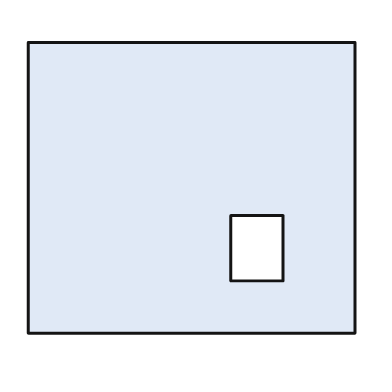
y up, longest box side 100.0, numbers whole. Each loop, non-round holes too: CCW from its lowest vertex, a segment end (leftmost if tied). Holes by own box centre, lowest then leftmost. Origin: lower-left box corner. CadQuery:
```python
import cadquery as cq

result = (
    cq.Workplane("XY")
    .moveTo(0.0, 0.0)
    .lineTo(100.0, 0.0)
    .lineTo(100.0, 89.0)
    .lineTo(0.0, 89.0)
    .close()
    .moveTo(62.0, 16.0)
    .lineTo(78.0, 16.0)
    .lineTo(78.0, 36.0)
    .lineTo(62.0, 36.0)
    .close()
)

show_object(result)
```